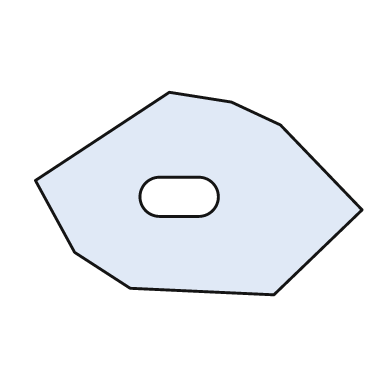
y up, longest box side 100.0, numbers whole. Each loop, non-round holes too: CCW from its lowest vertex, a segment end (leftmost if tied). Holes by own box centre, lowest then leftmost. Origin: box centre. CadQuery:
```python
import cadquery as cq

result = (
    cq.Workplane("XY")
    .moveTo(23.0, -31.0)
    .lineTo(50.0, -5.0)
    .lineTo(25.0, 21.0)
    .lineTo(10.0, 28.0)
    .lineTo(-9.0, 31.0)
    .lineTo(-50.0, 4.0)
    .lineTo(-38.0, -18.0)
    .lineTo(-21.0, -29.0)
    .close()
    .moveTo(-12.0, -7.0)
    .lineTo(0.0, -7.0)
    .threePointArc((6.0, -1.0), (0.0, 5.0))
    .lineTo(-12.0, 5.0)
    .threePointArc((-18.0, -1.0), (-12.0, -7.0))
    .close()
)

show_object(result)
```